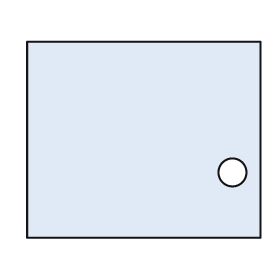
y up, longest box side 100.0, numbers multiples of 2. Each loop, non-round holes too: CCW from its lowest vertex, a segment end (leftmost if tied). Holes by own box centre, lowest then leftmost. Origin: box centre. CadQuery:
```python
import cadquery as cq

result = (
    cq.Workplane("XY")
    .moveTo(-50.0, -42.0)
    .lineTo(50.0, -42.0)
    .lineTo(50.0, 42.0)
    .lineTo(-50.0, 42.0)
    .close()
    .moveTo(38.0, -14.0)
    .circle(6.0)
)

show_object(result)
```